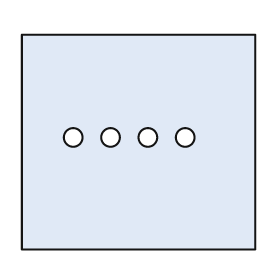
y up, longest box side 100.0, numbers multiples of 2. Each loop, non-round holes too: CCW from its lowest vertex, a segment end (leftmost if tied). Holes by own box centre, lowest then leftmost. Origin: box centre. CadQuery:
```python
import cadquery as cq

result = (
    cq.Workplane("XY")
    .moveTo(-50.0, -46.0)
    .lineTo(50.0, -46.0)
    .lineTo(50.0, 46.0)
    .lineTo(-50.0, 46.0)
    .close()
    .moveTo(-28.0, 2.0)
    .circle(4.0)
    .moveTo(-12.0, 2.0)
    .circle(4.0)
    .moveTo(4.0, 2.0)
    .circle(4.0)
    .moveTo(20.0, 2.0)
    .circle(4.0)
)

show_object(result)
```